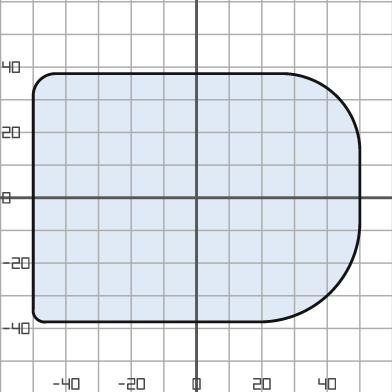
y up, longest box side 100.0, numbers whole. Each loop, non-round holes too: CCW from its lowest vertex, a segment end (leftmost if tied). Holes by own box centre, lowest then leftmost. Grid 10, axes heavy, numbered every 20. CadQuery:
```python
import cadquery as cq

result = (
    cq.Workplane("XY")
    .moveTo(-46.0, -38.0)
    .lineTo(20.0, -38.0)
    .threePointArc((41.0, -29.0), (50.0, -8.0))
    .lineTo(50.0, 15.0)
    .threePointArc((43.0, 31.0), (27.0, 38.0))
    .lineTo(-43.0, 38.0)
    .threePointArc((-48.0, 36.0), (-50.0, 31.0))
    .lineTo(-50.0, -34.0)
    .threePointArc((-49.0, -37.0), (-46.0, -38.0))
    .close()
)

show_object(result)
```